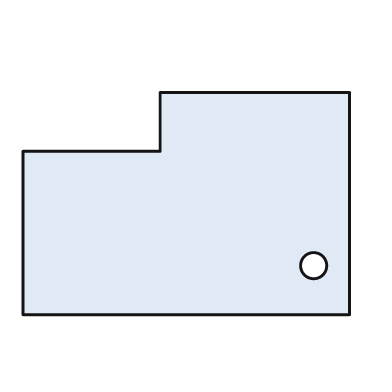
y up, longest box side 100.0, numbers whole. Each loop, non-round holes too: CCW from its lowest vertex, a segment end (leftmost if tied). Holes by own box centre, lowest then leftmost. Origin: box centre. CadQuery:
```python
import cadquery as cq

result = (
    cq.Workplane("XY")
    .moveTo(-50.0, -34.0)
    .lineTo(50.0, -34.0)
    .lineTo(50.0, 34.0)
    .lineTo(-8.0, 34.0)
    .lineTo(-8.0, 16.0)
    .lineTo(-50.0, 16.0)
    .close()
    .moveTo(39.0, -19.0)
    .circle(4.0)
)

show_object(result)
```